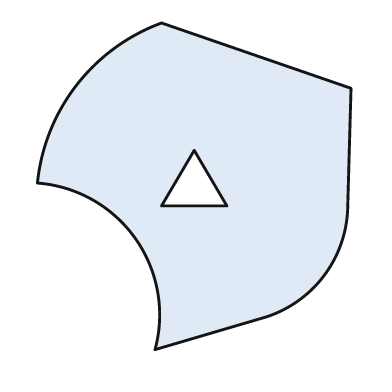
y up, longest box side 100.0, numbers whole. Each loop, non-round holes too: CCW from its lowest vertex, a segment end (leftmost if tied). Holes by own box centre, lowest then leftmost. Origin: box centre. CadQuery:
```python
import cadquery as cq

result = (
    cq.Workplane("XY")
    .moveTo(-12.0, -50.0)
    .lineTo(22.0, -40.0)
    .threePointArc((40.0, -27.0), (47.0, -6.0))
    .lineTo(48.0, 30.0)
    .lineTo(-10.0, 50.0)
    .threePointArc((-36.0, 31.0), (-48.0, 1.0))
    .threePointArc((-18.0, -16.0), (-12.0, -50.0))
    .close()
    .moveTo(-10.0, -6.0)
    .lineTo(10.0, -6.0)
    .lineTo(0.0, 11.0)
    .close()
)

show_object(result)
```